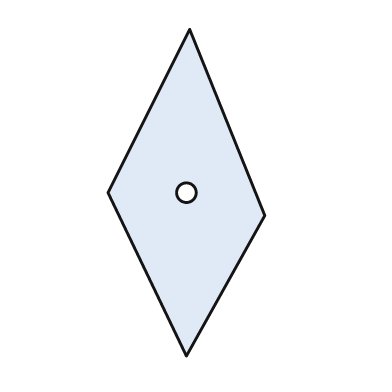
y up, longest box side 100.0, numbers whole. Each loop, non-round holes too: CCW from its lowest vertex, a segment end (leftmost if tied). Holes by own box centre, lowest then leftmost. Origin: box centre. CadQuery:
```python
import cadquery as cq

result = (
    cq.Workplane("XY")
    .moveTo(0.0, -50.0)
    .lineTo(24.0, -7.0)
    .lineTo(1.0, 50.0)
    .lineTo(-24.0, 0.0)
    .close()
    .moveTo(0.0, 0.0)
    .circle(3.0)
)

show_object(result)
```